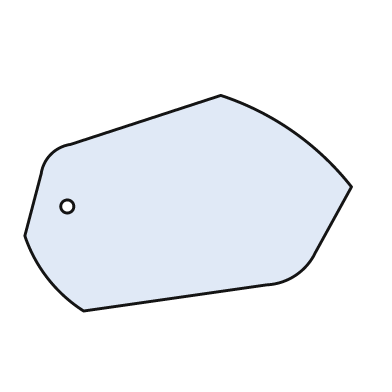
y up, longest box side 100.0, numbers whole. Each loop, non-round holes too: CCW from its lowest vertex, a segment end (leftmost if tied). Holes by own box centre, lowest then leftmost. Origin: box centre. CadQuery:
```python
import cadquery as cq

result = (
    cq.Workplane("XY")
    .moveTo(-32.0, -33.0)
    .lineTo(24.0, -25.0)
    .threePointArc((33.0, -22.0), (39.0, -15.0))
    .lineTo(50.0, 5.0)
    .threePointArc((32.0, 22.0), (10.0, 33.0))
    .lineTo(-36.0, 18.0)
    .threePointArc((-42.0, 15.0), (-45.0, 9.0))
    .lineTo(-50.0, -10.0)
    .threePointArc((-43.0, -23.0), (-32.0, -33.0))
    .close()
    .moveTo(-37.0, -1.0)
    .circle(2.0)
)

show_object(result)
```